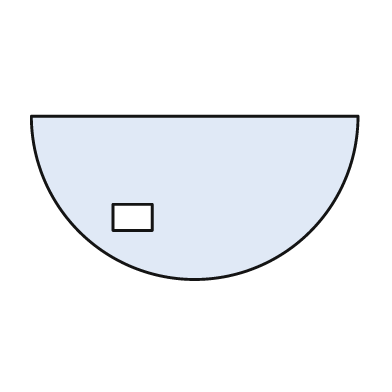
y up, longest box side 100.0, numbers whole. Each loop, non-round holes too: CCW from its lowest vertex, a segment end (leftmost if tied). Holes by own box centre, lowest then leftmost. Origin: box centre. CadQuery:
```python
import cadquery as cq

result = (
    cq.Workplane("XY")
    .moveTo(-50.0, 25.0)
    .threePointArc((0.0, -25.0), (50.0, 25.0))
    .close()
    .moveTo(-25.0, -10.0)
    .lineTo(-13.0, -10.0)
    .lineTo(-13.0, -2.0)
    .lineTo(-25.0, -2.0)
    .close()
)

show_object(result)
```